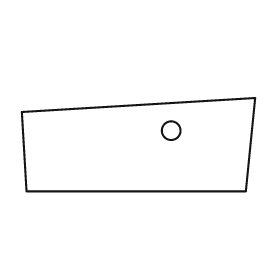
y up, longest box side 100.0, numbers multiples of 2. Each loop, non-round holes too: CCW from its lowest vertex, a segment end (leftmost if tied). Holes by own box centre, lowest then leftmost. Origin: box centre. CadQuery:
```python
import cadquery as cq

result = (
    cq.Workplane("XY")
    .moveTo(-48.0, -20.0)
    .lineTo(46.0, -20.0)
    .lineTo(50.0, 20.0)
    .lineTo(-50.0, 14.0)
    .close()
    .moveTo(14.0, 6.0)
    .circle(4.0)
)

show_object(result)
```